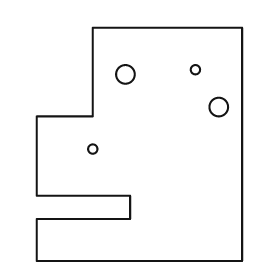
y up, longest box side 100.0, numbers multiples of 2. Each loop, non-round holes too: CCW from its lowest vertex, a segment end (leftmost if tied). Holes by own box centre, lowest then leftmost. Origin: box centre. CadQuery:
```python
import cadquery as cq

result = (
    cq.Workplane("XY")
    .moveTo(-44.0, -50.0)
    .lineTo(44.0, -50.0)
    .lineTo(44.0, 50.0)
    .lineTo(-20.0, 50.0)
    .lineTo(-20.0, 12.0)
    .lineTo(-44.0, 12.0)
    .lineTo(-44.0, -22.0)
    .lineTo(-4.0, -22.0)
    .lineTo(-4.0, -32.0)
    .lineTo(-44.0, -32.0)
    .close()
    .moveTo(-20.0, -2.0)
    .circle(2.0)
    .moveTo(34.0, 16.0)
    .circle(4.0)
    .moveTo(-6.0, 30.0)
    .circle(4.0)
    .moveTo(24.0, 32.0)
    .circle(2.0)
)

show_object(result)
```